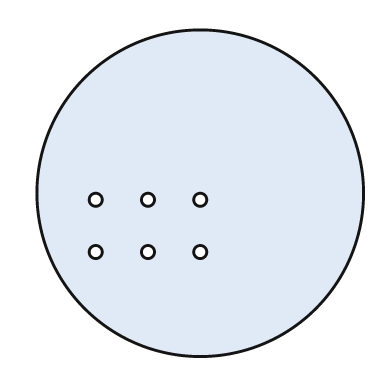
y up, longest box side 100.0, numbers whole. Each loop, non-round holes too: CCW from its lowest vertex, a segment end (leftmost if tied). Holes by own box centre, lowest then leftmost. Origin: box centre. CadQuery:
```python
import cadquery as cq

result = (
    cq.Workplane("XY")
    .moveTo(0.0, 0.0)
    .circle(50.0)
    .moveTo(-32.0, -18.0)
    .circle(2.0)
    .moveTo(-16.0, -18.0)
    .circle(2.0)
    .moveTo(0.0, -18.0)
    .circle(2.0)
    .moveTo(-32.0, -2.0)
    .circle(2.0)
    .moveTo(-16.0, -2.0)
    .circle(2.0)
    .moveTo(0.0, -2.0)
    .circle(2.0)
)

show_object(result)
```